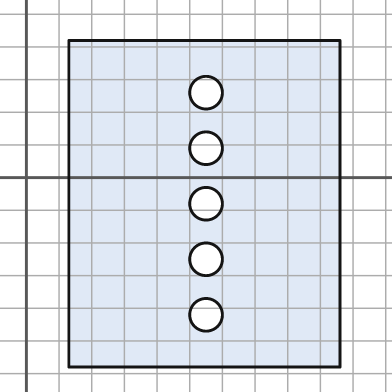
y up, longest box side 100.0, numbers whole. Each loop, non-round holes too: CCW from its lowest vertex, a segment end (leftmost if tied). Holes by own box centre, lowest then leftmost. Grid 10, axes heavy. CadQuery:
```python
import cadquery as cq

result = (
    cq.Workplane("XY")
    .moveTo(13.0, -58.0)
    .lineTo(96.0, -58.0)
    .lineTo(96.0, 42.0)
    .lineTo(13.0, 42.0)
    .close()
    .moveTo(55.0, -42.0)
    .circle(5.0)
    .moveTo(55.0, -25.0)
    .circle(5.0)
    .moveTo(55.0, -8.0)
    .circle(5.0)
    .moveTo(55.0, 9.0)
    .circle(5.0)
    .moveTo(55.0, 26.0)
    .circle(5.0)
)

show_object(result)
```